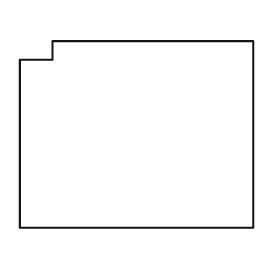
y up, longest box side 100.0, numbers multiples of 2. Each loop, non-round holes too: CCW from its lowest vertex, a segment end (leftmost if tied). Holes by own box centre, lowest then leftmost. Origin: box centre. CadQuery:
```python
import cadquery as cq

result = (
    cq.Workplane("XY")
    .moveTo(-50.0, -40.0)
    .lineTo(50.0, -40.0)
    .lineTo(50.0, 40.0)
    .lineTo(-36.0, 40.0)
    .lineTo(-36.0, 32.0)
    .lineTo(-50.0, 32.0)
    .close()
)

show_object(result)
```